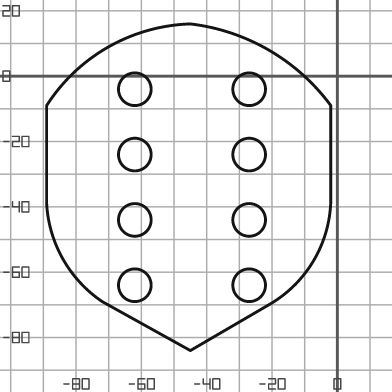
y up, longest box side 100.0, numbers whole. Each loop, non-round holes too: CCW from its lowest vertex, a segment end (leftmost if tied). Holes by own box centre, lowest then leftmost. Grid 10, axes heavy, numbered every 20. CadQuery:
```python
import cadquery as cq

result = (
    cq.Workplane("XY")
    .moveTo(-45.0, -84.0)
    .lineTo(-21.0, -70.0)
    .threePointArc((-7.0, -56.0), (-2.0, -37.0))
    .lineTo(-2.0, -9.0)
    .threePointArc((-21.0, 8.0), (-45.0, 16.0))
    .threePointArc((-70.0, 9.0), (-89.0, -9.0))
    .lineTo(-89.0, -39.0)
    .threePointArc((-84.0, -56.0), (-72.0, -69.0))
    .close()
    .moveTo(-62.0, -64.0)
    .circle(5.0)
    .moveTo(-27.0, -64.0)
    .circle(5.0)
    .moveTo(-62.0, -44.0)
    .circle(5.0)
    .moveTo(-27.0, -44.0)
    .circle(5.0)
    .moveTo(-62.0, -24.0)
    .circle(5.0)
    .moveTo(-27.0, -24.0)
    .circle(5.0)
    .moveTo(-62.0, -4.0)
    .circle(5.0)
    .moveTo(-27.0, -4.0)
    .circle(5.0)
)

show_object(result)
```